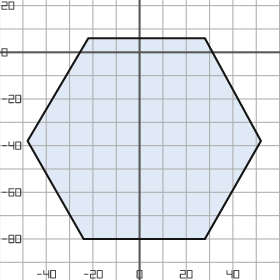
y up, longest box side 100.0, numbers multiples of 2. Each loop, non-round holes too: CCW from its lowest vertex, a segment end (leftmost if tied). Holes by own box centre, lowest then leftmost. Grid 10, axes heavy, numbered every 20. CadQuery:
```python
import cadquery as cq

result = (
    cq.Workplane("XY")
    .moveTo(-24.0, -80.0)
    .lineTo(28.0, -80.0)
    .lineTo(52.0, -38.0)
    .lineTo(28.0, 6.0)
    .lineTo(-22.0, 6.0)
    .lineTo(-48.0, -38.0)
    .close()
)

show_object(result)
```